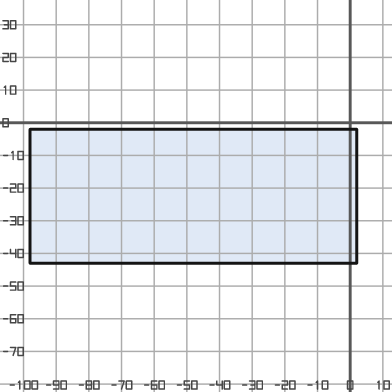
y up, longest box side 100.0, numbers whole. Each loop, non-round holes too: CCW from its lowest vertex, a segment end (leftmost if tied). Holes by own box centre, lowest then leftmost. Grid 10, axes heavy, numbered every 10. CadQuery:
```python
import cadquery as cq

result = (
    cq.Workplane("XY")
    .moveTo(-98.0, -43.0)
    .lineTo(2.0, -43.0)
    .lineTo(2.0, -2.0)
    .lineTo(-98.0, -2.0)
    .close()
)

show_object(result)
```